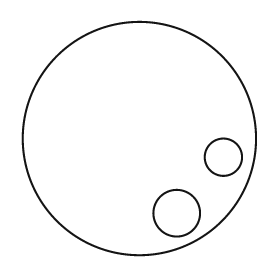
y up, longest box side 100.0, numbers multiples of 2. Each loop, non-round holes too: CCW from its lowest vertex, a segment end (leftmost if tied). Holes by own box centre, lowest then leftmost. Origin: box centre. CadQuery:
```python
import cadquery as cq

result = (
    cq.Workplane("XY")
    .moveTo(0.0, 0.0)
    .circle(50.0)
    .moveTo(16.0, -32.0)
    .circle(10.0)
    .moveTo(36.0, -8.0)
    .circle(8.0)
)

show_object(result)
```